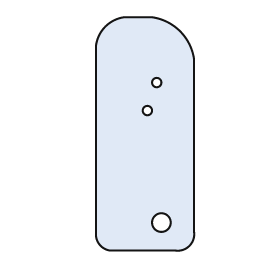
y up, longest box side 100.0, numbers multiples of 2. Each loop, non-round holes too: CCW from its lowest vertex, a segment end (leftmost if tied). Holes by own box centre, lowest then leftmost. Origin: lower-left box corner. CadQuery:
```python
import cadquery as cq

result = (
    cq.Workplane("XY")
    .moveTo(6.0, 0.0)
    .lineTo(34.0, 0.0)
    .threePointArc((40.0, 2.0), (42.0, 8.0))
    .lineTo(42.0, 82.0)
    .threePointArc((36.0, 94.0), (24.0, 100.0))
    .lineTo(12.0, 100.0)
    .threePointArc((4.0, 96.0), (0.0, 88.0))
    .lineTo(0.0, 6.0)
    .threePointArc((2.0, 2.0), (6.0, 0.0))
    .close()
    .moveTo(28.0, 12.0)
    .circle(4.0)
    .moveTo(22.0, 60.0)
    .circle(2.0)
    .moveTo(26.0, 72.0)
    .circle(2.0)
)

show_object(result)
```